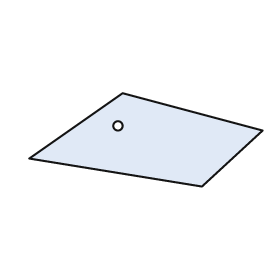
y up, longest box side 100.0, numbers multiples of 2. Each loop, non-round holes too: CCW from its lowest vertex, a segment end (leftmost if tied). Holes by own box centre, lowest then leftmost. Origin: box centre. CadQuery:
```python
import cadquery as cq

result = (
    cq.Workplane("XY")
    .moveTo(24.0, -20.0)
    .lineTo(50.0, 4.0)
    .lineTo(-10.0, 20.0)
    .lineTo(-50.0, -8.0)
    .close()
    .moveTo(-12.0, 6.0)
    .circle(2.0)
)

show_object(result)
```